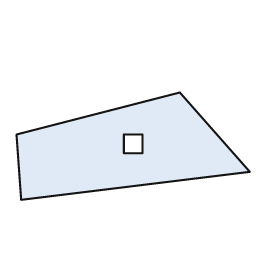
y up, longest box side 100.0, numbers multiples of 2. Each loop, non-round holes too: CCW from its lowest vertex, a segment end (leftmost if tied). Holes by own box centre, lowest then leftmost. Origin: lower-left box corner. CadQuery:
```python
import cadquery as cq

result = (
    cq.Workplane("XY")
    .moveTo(2.0, 0.0)
    .lineTo(100.0, 12.0)
    .lineTo(70.0, 46.0)
    .lineTo(0.0, 28.0)
    .close()
    .moveTo(46.0, 20.0)
    .lineTo(54.0, 20.0)
    .lineTo(54.0, 28.0)
    .lineTo(46.0, 28.0)
    .close()
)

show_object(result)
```